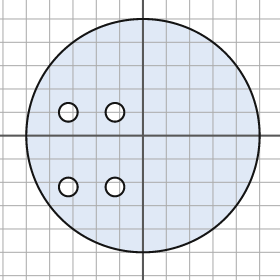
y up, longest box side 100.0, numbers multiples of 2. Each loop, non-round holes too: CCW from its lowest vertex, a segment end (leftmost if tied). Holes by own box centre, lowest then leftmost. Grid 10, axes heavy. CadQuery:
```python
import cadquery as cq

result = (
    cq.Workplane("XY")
    .moveTo(0.0, 0.0)
    .circle(50.0)
    .moveTo(-32.0, -22.0)
    .circle(4.0)
    .moveTo(-12.0, -22.0)
    .circle(4.0)
    .moveTo(-32.0, 10.0)
    .circle(4.0)
    .moveTo(-12.0, 10.0)
    .circle(4.0)
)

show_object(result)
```